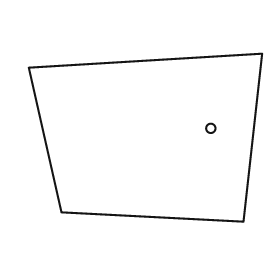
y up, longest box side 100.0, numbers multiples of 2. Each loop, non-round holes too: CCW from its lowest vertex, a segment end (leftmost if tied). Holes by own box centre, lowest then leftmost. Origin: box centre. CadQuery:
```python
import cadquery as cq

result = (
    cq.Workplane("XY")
    .moveTo(42.0, -36.0)
    .lineTo(50.0, 36.0)
    .lineTo(-50.0, 30.0)
    .lineTo(-36.0, -32.0)
    .close()
    .moveTo(28.0, 4.0)
    .circle(2.0)
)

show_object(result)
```